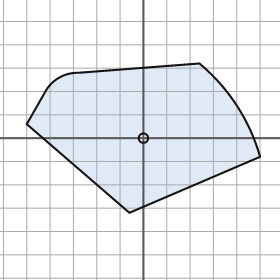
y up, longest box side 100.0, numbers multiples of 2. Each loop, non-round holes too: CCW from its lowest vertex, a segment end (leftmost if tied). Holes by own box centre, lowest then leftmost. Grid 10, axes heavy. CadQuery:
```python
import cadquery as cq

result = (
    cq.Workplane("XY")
    .moveTo(-6.0, -32.0)
    .lineTo(50.0, -8.0)
    .threePointArc((40.0, 14.0), (24.0, 32.0))
    .lineTo(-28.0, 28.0)
    .threePointArc((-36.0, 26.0), (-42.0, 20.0))
    .lineTo(-50.0, 6.0)
    .close()
    .moveTo(0.0, 0.0)
    .circle(2.0)
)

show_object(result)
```